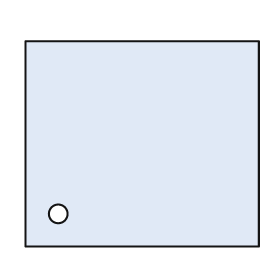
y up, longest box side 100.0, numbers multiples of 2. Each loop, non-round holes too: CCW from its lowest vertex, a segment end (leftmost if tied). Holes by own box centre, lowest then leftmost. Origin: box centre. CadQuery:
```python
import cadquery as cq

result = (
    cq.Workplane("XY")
    .moveTo(-50.0, -44.0)
    .lineTo(50.0, -44.0)
    .lineTo(50.0, 44.0)
    .lineTo(-50.0, 44.0)
    .close()
    .moveTo(-36.0, -30.0)
    .circle(4.0)
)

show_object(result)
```